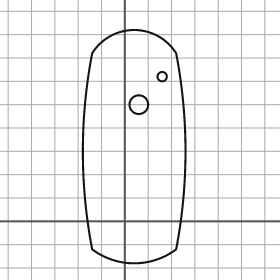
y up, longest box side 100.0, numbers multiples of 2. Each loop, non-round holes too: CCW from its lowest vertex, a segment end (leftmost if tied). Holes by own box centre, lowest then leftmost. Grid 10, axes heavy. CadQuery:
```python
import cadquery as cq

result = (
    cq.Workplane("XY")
    .moveTo(-14.0, -12.0)
    .threePointArc((4.0, -18.0), (22.0, -12.0))
    .threePointArc((26.0, 30.0), (22.0, 72.0))
    .threePointArc((4.0, 82.0), (-14.0, 72.0))
    .threePointArc((-18.0, 30.0), (-14.0, -12.0))
    .close()
    .moveTo(6.0, 50.0)
    .circle(4.0)
    .moveTo(16.0, 62.0)
    .circle(2.0)
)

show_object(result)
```